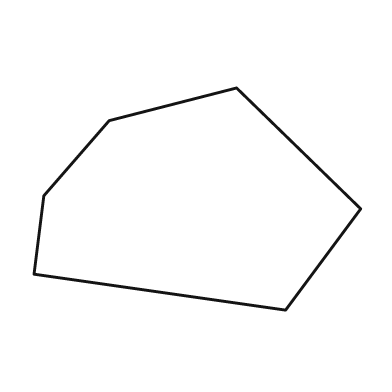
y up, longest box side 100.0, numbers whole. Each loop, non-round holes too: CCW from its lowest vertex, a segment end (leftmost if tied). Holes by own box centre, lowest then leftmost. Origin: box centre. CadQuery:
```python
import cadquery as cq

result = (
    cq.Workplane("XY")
    .moveTo(27.0, -34.0)
    .lineTo(50.0, -3.0)
    .lineTo(12.0, 34.0)
    .lineTo(-27.0, 24.0)
    .lineTo(-47.0, 1.0)
    .lineTo(-50.0, -23.0)
    .close()
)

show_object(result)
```